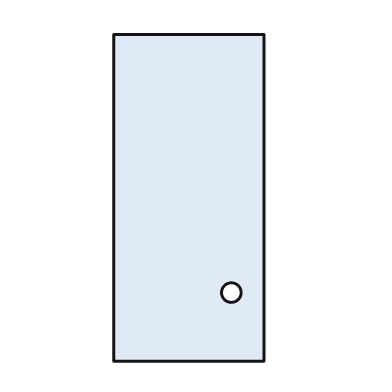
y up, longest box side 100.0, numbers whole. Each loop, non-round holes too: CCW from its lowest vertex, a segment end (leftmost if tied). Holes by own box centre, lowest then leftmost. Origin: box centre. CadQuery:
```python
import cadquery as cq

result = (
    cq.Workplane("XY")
    .moveTo(-23.0, -50.0)
    .lineTo(23.0, -50.0)
    .lineTo(23.0, 50.0)
    .lineTo(-23.0, 50.0)
    .close()
    .moveTo(13.0, -29.0)
    .circle(3.0)
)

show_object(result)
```